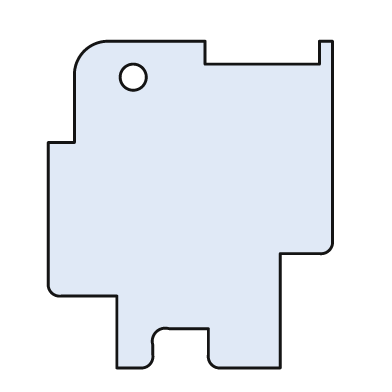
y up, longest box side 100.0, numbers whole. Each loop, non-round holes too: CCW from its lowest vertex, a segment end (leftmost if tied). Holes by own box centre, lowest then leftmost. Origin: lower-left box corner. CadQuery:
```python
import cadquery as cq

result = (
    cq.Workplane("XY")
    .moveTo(21.0, 0.0)
    .lineTo(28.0, 0.0)
    .threePointArc((31.0, 1.0), (32.0, 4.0))
    .lineTo(32.0, 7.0)
    .threePointArc((33.0, 11.0), (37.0, 12.0))
    .lineTo(49.0, 12.0)
    .lineTo(49.0, 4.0)
    .threePointArc((50.0, 1.0), (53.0, 0.0))
    .lineTo(71.0, 0.0)
    .lineTo(71.0, 35.0)
    .lineTo(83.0, 35.0)
    .threePointArc((86.0, 36.0), (87.0, 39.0))
    .lineTo(87.0, 100.0)
    .lineTo(83.0, 100.0)
    .lineTo(83.0, 93.0)
    .lineTo(48.0, 93.0)
    .lineTo(48.0, 100.0)
    .lineTo(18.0, 100.0)
    .threePointArc((11.0, 97.0), (8.0, 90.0))
    .lineTo(8.0, 69.0)
    .lineTo(0.0, 69.0)
    .lineTo(0.0, 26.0)
    .threePointArc((1.0, 23.0), (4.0, 22.0))
    .lineTo(21.0, 22.0)
    .close()
    .moveTo(26.0, 89.0)
    .circle(4.0)
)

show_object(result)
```